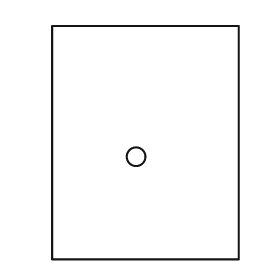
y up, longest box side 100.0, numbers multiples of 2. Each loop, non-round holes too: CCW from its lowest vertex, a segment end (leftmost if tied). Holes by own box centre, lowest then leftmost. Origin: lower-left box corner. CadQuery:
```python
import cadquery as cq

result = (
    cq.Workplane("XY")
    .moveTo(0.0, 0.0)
    .lineTo(80.0, 0.0)
    .lineTo(80.0, 100.0)
    .lineTo(0.0, 100.0)
    .close()
    .moveTo(36.0, 44.0)
    .circle(4.0)
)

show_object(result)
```